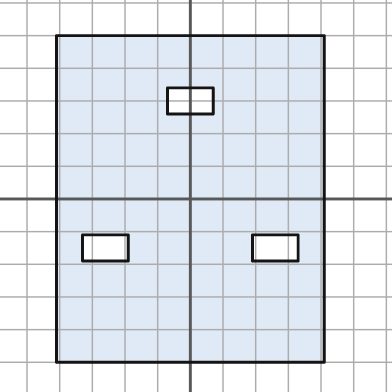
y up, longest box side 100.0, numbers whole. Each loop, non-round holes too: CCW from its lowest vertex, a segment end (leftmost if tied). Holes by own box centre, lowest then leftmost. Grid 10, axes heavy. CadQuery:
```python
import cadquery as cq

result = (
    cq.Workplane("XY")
    .moveTo(-41.0, -50.0)
    .lineTo(41.0, -50.0)
    .lineTo(41.0, 50.0)
    .lineTo(-41.0, 50.0)
    .close()
    .moveTo(-33.0, -19.0)
    .lineTo(-19.0, -19.0)
    .lineTo(-19.0, -11.0)
    .lineTo(-33.0, -11.0)
    .close()
    .moveTo(19.0, -19.0)
    .lineTo(33.0, -19.0)
    .lineTo(33.0, -11.0)
    .lineTo(19.0, -11.0)
    .close()
    .moveTo(-7.0, 26.0)
    .lineTo(7.0, 26.0)
    .lineTo(7.0, 34.0)
    .lineTo(-7.0, 34.0)
    .close()
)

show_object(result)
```